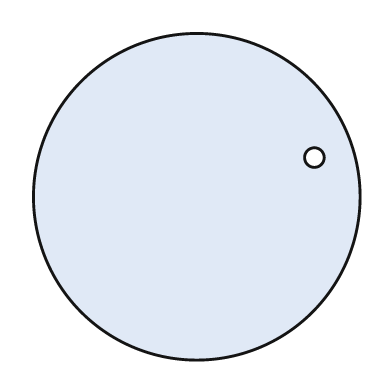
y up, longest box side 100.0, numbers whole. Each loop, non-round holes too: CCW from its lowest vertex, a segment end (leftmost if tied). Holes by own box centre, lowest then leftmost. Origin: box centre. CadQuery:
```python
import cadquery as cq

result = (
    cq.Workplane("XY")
    .moveTo(0.0, 0.0)
    .circle(50.0)
    .moveTo(36.0, 12.0)
    .circle(3.0)
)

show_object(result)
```